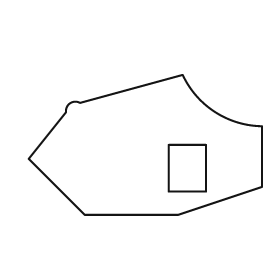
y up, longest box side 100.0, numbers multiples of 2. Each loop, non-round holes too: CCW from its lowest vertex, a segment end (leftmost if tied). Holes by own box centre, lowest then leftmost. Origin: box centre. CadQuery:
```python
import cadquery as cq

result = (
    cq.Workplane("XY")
    .moveTo(-26.0, -30.0)
    .lineTo(14.0, -30.0)
    .lineTo(50.0, -18.0)
    .lineTo(50.0, 8.0)
    .threePointArc((30.0, 14.0), (16.0, 30.0))
    .lineTo(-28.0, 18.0)
    .threePointArc((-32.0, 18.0), (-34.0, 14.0))
    .lineTo(-50.0, -6.0)
    .close()
    .moveTo(10.0, -20.0)
    .lineTo(26.0, -20.0)
    .lineTo(26.0, 0.0)
    .lineTo(10.0, 0.0)
    .close()
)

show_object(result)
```